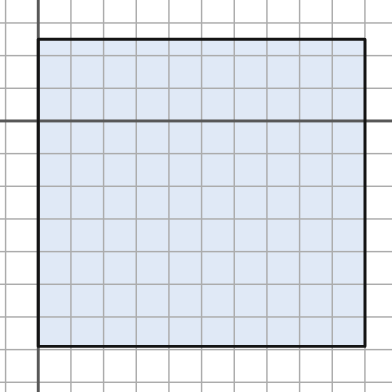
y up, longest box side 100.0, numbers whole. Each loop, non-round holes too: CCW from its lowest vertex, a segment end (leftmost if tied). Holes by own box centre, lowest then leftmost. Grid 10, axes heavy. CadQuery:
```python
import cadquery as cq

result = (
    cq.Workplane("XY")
    .moveTo(0.0, -69.0)
    .lineTo(100.0, -69.0)
    .lineTo(100.0, 25.0)
    .lineTo(0.0, 25.0)
    .close()
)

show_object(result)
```